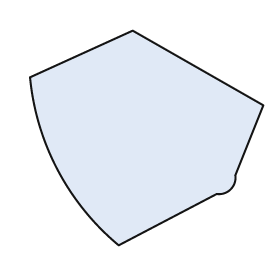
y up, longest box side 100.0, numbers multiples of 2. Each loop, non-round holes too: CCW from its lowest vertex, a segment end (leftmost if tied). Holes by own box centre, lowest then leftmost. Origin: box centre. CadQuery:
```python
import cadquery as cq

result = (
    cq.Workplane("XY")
    .moveTo(-12.0, -46.0)
    .lineTo(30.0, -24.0)
    .threePointArc((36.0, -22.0), (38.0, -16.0))
    .lineTo(50.0, 14.0)
    .lineTo(-6.0, 46.0)
    .lineTo(-50.0, 26.0)
    .threePointArc((-38.0, -14.0), (-12.0, -46.0))
    .close()
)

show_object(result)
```